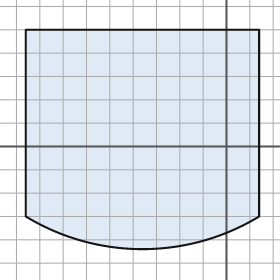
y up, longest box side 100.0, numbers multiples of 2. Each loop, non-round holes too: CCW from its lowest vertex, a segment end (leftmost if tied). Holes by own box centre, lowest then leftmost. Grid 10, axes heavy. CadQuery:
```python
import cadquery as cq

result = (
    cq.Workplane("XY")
    .moveTo(-86.0, -30.0)
    .threePointArc((-36.0, -44.0), (14.0, -30.0))
    .lineTo(14.0, 50.0)
    .lineTo(-86.0, 50.0)
    .close()
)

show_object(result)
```